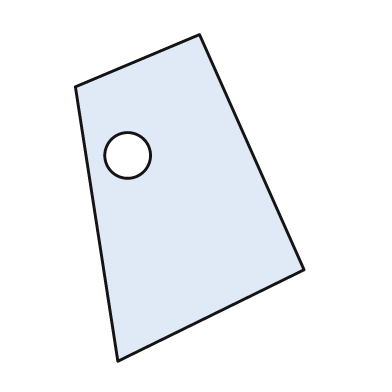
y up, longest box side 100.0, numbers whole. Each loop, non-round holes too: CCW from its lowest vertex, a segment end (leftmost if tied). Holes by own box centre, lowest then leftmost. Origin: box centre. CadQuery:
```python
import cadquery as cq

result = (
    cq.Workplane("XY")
    .moveTo(-22.0, -50.0)
    .lineTo(35.0, -22.0)
    .lineTo(3.0, 50.0)
    .lineTo(-35.0, 34.0)
    .close()
    .moveTo(-19.0, 13.0)
    .circle(7.0)
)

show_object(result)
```